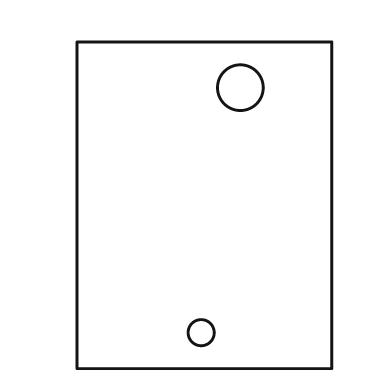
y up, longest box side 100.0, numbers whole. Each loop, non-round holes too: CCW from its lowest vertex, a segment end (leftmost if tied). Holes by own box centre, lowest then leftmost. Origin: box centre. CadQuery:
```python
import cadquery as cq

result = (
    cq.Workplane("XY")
    .moveTo(-39.0, -50.0)
    .lineTo(39.0, -50.0)
    .lineTo(39.0, 50.0)
    .lineTo(-39.0, 50.0)
    .close()
    .moveTo(-1.0, -39.0)
    .circle(4.0)
    .moveTo(11.0, 36.0)
    .circle(7.0)
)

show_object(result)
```